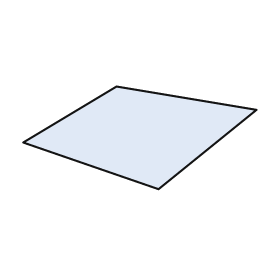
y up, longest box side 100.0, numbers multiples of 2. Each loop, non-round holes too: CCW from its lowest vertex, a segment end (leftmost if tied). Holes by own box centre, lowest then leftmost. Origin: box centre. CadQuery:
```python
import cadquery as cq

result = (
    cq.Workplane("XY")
    .moveTo(8.0, -22.0)
    .lineTo(50.0, 12.0)
    .lineTo(-10.0, 22.0)
    .lineTo(-50.0, -2.0)
    .close()
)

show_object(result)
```